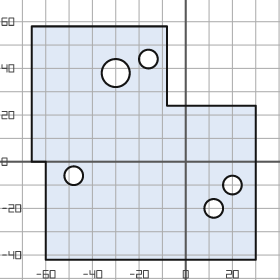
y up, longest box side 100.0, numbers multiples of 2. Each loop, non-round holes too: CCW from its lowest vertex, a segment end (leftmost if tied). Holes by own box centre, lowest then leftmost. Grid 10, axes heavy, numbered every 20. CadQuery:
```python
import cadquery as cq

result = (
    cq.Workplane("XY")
    .moveTo(-60.0, -42.0)
    .lineTo(30.0, -42.0)
    .lineTo(30.0, 24.0)
    .lineTo(-8.0, 24.0)
    .lineTo(-8.0, 58.0)
    .lineTo(-66.0, 58.0)
    .lineTo(-66.0, 0.0)
    .lineTo(-60.0, 0.0)
    .close()
    .moveTo(12.0, -20.0)
    .circle(4.0)
    .moveTo(20.0, -10.0)
    .circle(4.0)
    .moveTo(-48.0, -6.0)
    .circle(4.0)
    .moveTo(-30.0, 38.0)
    .circle(6.0)
    .moveTo(-16.0, 44.0)
    .circle(4.0)
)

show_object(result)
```